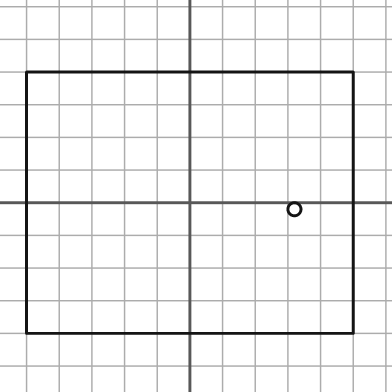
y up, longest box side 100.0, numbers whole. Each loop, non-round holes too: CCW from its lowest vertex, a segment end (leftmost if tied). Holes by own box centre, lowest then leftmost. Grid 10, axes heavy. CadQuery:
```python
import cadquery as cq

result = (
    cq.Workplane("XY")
    .moveTo(-50.0, -40.0)
    .lineTo(50.0, -40.0)
    .lineTo(50.0, 40.0)
    .lineTo(-50.0, 40.0)
    .close()
    .moveTo(32.0, -2.0)
    .circle(2.0)
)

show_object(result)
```